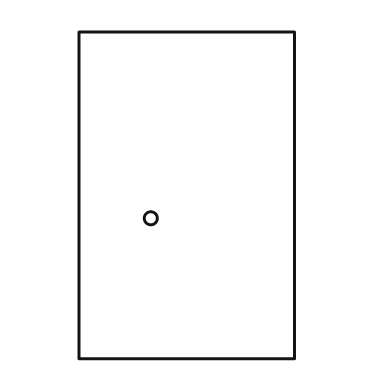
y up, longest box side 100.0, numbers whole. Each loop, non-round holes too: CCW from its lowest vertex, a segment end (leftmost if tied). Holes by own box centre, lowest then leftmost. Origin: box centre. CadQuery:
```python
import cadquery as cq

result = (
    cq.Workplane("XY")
    .moveTo(-33.0, -50.0)
    .lineTo(33.0, -50.0)
    .lineTo(33.0, 50.0)
    .lineTo(-33.0, 50.0)
    .close()
    .moveTo(-11.0, -7.0)
    .circle(2.0)
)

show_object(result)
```